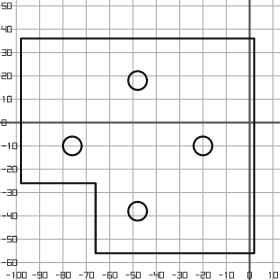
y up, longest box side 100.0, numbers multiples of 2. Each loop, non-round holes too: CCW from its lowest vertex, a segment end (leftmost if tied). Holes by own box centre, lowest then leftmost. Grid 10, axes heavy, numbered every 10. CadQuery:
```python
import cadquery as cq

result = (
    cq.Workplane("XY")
    .moveTo(-66.0, -56.0)
    .lineTo(2.0, -56.0)
    .lineTo(2.0, 36.0)
    .lineTo(-98.0, 36.0)
    .lineTo(-98.0, -26.0)
    .lineTo(-66.0, -26.0)
    .close()
    .moveTo(-48.0, -38.0)
    .circle(4.0)
    .moveTo(-76.0, -10.0)
    .circle(4.0)
    .moveTo(-20.0, -10.0)
    .circle(4.0)
    .moveTo(-48.0, 18.0)
    .circle(4.0)
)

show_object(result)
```